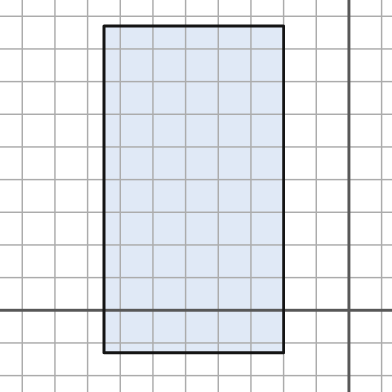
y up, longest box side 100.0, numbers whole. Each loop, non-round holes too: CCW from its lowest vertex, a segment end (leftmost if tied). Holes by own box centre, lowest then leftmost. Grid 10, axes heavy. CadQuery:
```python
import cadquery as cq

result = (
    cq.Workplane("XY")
    .moveTo(-75.0, -13.0)
    .lineTo(-20.0, -13.0)
    .lineTo(-20.0, 87.0)
    .lineTo(-75.0, 87.0)
    .close()
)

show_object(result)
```